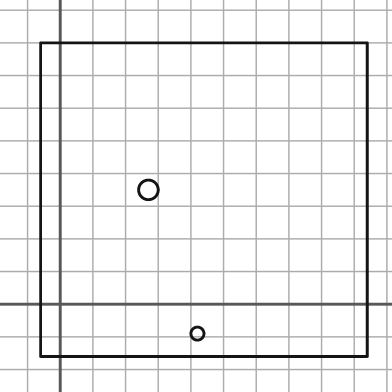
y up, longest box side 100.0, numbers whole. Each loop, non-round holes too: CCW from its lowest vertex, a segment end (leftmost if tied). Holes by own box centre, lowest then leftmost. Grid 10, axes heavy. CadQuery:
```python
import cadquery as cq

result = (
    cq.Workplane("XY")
    .moveTo(-6.0, -16.0)
    .lineTo(94.0, -16.0)
    .lineTo(94.0, 80.0)
    .lineTo(-6.0, 80.0)
    .close()
    .moveTo(42.0, -9.0)
    .circle(2.0)
    .moveTo(27.0, 35.0)
    .circle(3.0)
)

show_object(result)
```